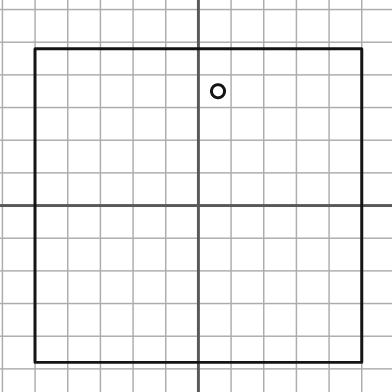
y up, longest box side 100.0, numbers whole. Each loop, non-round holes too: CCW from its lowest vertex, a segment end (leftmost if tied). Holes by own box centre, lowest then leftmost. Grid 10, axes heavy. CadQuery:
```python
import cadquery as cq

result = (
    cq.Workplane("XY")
    .moveTo(-50.0, -48.0)
    .lineTo(50.0, -48.0)
    .lineTo(50.0, 48.0)
    .lineTo(-50.0, 48.0)
    .close()
    .moveTo(6.0, 35.0)
    .circle(2.0)
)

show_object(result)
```